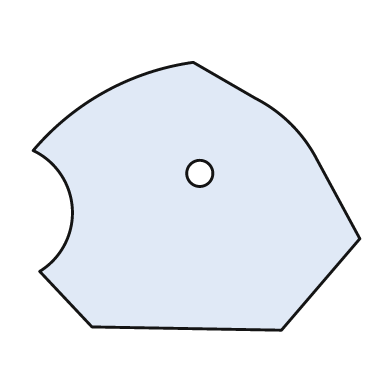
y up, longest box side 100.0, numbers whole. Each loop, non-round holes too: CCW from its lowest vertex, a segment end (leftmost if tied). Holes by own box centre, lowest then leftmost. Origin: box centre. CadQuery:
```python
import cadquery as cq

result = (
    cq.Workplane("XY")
    .moveTo(26.0, -41.0)
    .lineTo(50.0, -13.0)
    .lineTo(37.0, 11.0)
    .threePointArc((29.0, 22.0), (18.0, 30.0))
    .lineTo(-1.0, 41.0)
    .threePointArc((-28.0, 32.0), (-50.0, 14.0))
    .threePointArc((-38.0, -4.0), (-48.0, -23.0))
    .lineTo(-32.0, -40.0)
    .close()
    .moveTo(1.0, 7.0)
    .circle(4.0)
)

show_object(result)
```